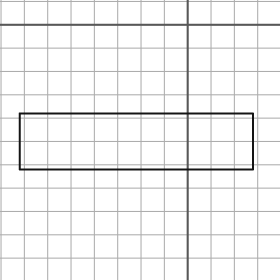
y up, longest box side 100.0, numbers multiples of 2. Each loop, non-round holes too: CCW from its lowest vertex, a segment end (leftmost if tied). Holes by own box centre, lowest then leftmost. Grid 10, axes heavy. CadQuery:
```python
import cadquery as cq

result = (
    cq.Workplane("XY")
    .moveTo(-72.0, -62.0)
    .lineTo(28.0, -62.0)
    .lineTo(28.0, -38.0)
    .lineTo(-72.0, -38.0)
    .close()
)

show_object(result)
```